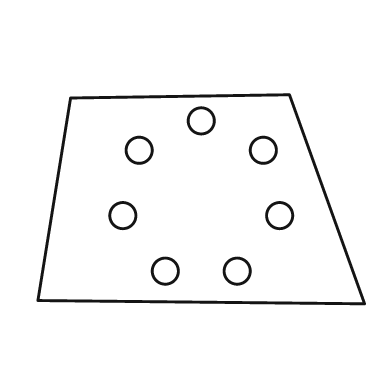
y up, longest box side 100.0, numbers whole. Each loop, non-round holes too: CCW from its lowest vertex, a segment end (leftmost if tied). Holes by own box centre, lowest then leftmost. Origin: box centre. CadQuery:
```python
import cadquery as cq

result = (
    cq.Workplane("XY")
    .moveTo(50.0, -32.0)
    .lineTo(27.0, 32.0)
    .lineTo(-40.0, 31.0)
    .lineTo(-50.0, -31.0)
    .close()
    .moveTo(-11.0, -22.0)
    .circle(4.0)
    .moveTo(11.0, -22.0)
    .circle(4.0)
    .moveTo(-24.0, -5.0)
    .circle(4.0)
    .moveTo(24.0, -5.0)
    .circle(4.0)
    .moveTo(-19.0, 15.0)
    .circle(4.0)
    .moveTo(19.0, 15.0)
    .circle(4.0)
    .moveTo(0.0, 24.0)
    .circle(4.0)
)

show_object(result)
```